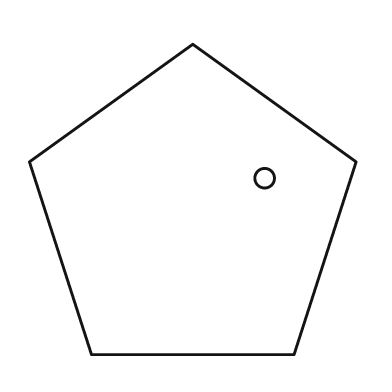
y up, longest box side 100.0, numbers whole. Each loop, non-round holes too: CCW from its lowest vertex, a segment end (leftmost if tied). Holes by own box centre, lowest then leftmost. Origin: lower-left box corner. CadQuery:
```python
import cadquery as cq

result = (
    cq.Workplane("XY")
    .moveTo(19.0, 0.0)
    .lineTo(81.0, 0.0)
    .lineTo(100.0, 59.0)
    .lineTo(50.0, 95.0)
    .lineTo(0.0, 59.0)
    .close()
    .moveTo(72.0, 54.0)
    .circle(3.0)
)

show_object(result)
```